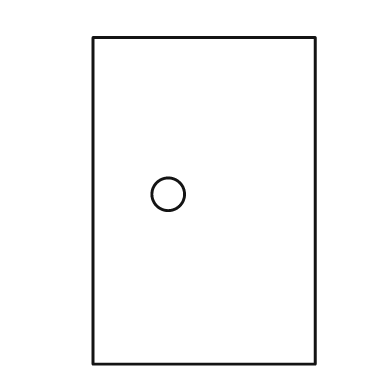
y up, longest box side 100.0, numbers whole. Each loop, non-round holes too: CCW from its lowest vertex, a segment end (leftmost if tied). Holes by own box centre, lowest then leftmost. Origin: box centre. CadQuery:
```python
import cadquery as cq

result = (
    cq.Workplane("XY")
    .moveTo(-34.0, -50.0)
    .lineTo(34.0, -50.0)
    .lineTo(34.0, 50.0)
    .lineTo(-34.0, 50.0)
    .close()
    .moveTo(-11.0, 2.0)
    .circle(5.0)
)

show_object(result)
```